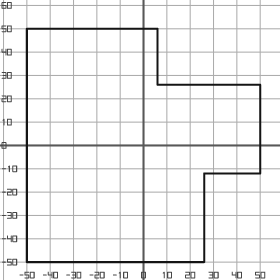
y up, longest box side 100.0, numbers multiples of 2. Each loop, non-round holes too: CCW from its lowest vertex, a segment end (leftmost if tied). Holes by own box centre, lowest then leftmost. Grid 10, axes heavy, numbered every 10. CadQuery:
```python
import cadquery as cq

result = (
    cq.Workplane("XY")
    .moveTo(-50.0, -50.0)
    .lineTo(26.0, -50.0)
    .lineTo(26.0, -12.0)
    .lineTo(50.0, -12.0)
    .lineTo(50.0, 26.0)
    .lineTo(6.0, 26.0)
    .lineTo(6.0, 50.0)
    .lineTo(-50.0, 50.0)
    .close()
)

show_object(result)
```